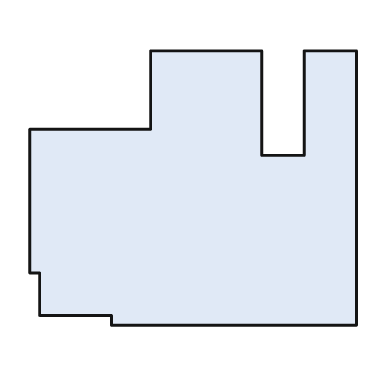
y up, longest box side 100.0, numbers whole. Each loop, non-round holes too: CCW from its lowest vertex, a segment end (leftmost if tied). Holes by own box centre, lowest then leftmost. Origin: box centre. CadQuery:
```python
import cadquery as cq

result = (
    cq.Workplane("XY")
    .moveTo(-25.0, -42.0)
    .lineTo(50.0, -42.0)
    .lineTo(50.0, 42.0)
    .lineTo(34.0, 42.0)
    .lineTo(34.0, 10.0)
    .lineTo(21.0, 10.0)
    .lineTo(21.0, 42.0)
    .lineTo(-13.0, 42.0)
    .lineTo(-13.0, 18.0)
    .lineTo(-50.0, 18.0)
    .lineTo(-50.0, -26.0)
    .lineTo(-47.0, -26.0)
    .lineTo(-47.0, -39.0)
    .lineTo(-25.0, -39.0)
    .close()
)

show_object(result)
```